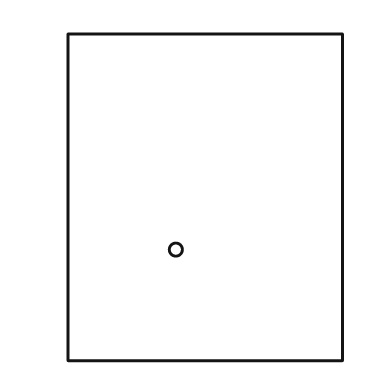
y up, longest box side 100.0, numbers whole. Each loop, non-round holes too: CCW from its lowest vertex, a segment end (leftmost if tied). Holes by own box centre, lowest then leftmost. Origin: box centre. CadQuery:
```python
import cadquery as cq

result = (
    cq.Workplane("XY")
    .moveTo(-42.0, -50.0)
    .lineTo(42.0, -50.0)
    .lineTo(42.0, 50.0)
    .lineTo(-42.0, 50.0)
    .close()
    .moveTo(-9.0, -16.0)
    .circle(2.0)
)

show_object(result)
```